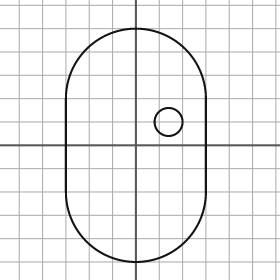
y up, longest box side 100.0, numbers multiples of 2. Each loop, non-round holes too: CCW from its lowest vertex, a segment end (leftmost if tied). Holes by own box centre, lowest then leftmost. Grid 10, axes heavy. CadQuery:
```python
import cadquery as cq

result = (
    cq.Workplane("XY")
    .moveTo(-30.0, -20.0)
    .threePointArc((0.0, -50.0), (30.0, -20.0))
    .lineTo(30.0, 20.0)
    .threePointArc((0.0, 50.0), (-30.0, 20.0))
    .close()
    .moveTo(14.0, 10.0)
    .circle(6.0)
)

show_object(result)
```